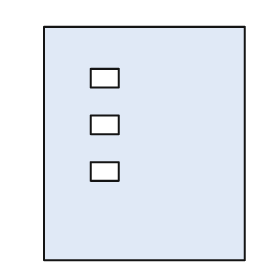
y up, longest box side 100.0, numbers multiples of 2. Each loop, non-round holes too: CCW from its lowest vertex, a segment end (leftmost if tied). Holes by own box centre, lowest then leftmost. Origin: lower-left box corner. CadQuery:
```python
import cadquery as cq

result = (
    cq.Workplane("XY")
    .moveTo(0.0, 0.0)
    .lineTo(86.0, 0.0)
    .lineTo(86.0, 100.0)
    .lineTo(0.0, 100.0)
    .close()
    .moveTo(20.0, 34.0)
    .lineTo(32.0, 34.0)
    .lineTo(32.0, 42.0)
    .lineTo(20.0, 42.0)
    .close()
    .moveTo(20.0, 54.0)
    .lineTo(32.0, 54.0)
    .lineTo(32.0, 62.0)
    .lineTo(20.0, 62.0)
    .close()
    .moveTo(20.0, 74.0)
    .lineTo(32.0, 74.0)
    .lineTo(32.0, 82.0)
    .lineTo(20.0, 82.0)
    .close()
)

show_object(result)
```